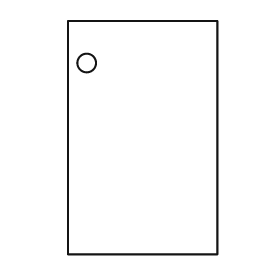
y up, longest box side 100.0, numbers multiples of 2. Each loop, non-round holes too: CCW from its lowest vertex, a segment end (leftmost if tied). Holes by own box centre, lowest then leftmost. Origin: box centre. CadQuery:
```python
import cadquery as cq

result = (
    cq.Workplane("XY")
    .moveTo(-32.0, -50.0)
    .lineTo(32.0, -50.0)
    .lineTo(32.0, 50.0)
    .lineTo(-32.0, 50.0)
    .close()
    .moveTo(-24.0, 32.0)
    .circle(4.0)
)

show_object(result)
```